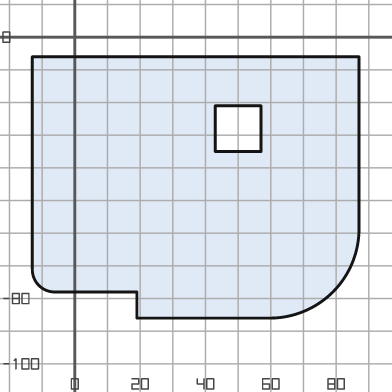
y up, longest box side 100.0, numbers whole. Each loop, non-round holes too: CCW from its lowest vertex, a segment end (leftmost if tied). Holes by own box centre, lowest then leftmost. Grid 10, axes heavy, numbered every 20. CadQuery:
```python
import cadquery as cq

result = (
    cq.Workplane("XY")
    .moveTo(19.0, -86.0)
    .lineTo(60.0, -86.0)
    .threePointArc((79.0, -78.0), (87.0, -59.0))
    .lineTo(87.0, -6.0)
    .lineTo(-13.0, -6.0)
    .lineTo(-13.0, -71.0)
    .threePointArc((-11.0, -76.0), (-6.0, -78.0))
    .lineTo(19.0, -78.0)
    .close()
    .moveTo(43.0, -35.0)
    .lineTo(57.0, -35.0)
    .lineTo(57.0, -21.0)
    .lineTo(43.0, -21.0)
    .close()
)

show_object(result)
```